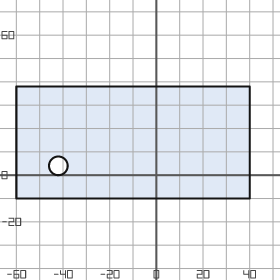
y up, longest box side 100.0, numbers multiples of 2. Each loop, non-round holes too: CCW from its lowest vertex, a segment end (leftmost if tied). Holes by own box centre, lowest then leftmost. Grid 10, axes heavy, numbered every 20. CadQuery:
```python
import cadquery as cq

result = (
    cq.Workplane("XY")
    .moveTo(-60.0, -10.0)
    .lineTo(40.0, -10.0)
    .lineTo(40.0, 38.0)
    .lineTo(-60.0, 38.0)
    .close()
    .moveTo(-42.0, 4.0)
    .circle(4.0)
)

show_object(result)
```